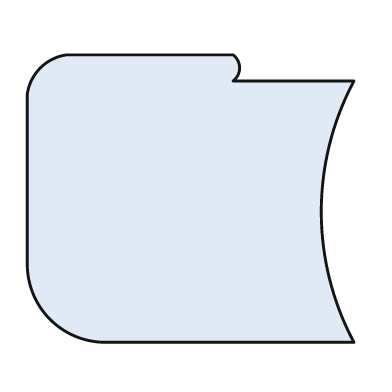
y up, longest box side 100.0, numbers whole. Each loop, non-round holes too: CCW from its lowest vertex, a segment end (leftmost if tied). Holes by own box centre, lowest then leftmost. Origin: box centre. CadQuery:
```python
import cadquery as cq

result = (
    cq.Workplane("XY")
    .moveTo(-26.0, -44.0)
    .lineTo(50.0, -44.0)
    .threePointArc((40.0, -4.0), (50.0, 36.0))
    .lineTo(13.0, 36.0)
    .threePointArc((15.0, 40.0), (13.0, 44.0))
    .lineTo(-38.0, 44.0)
    .threePointArc((-46.0, 40.0), (-50.0, 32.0))
    .lineTo(-50.0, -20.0)
    .threePointArc((-43.0, -37.0), (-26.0, -44.0))
    .close()
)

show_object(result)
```